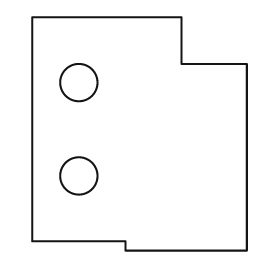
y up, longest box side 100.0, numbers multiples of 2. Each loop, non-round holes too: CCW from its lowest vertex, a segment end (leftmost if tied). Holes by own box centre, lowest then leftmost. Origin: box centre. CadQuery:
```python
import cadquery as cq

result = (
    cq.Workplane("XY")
    .moveTo(-6.0, -50.0)
    .lineTo(46.0, -50.0)
    .lineTo(46.0, 30.0)
    .lineTo(18.0, 30.0)
    .lineTo(18.0, 50.0)
    .lineTo(-46.0, 50.0)
    .lineTo(-46.0, -46.0)
    .lineTo(-6.0, -46.0)
    .close()
    .moveTo(-26.0, -18.0)
    .circle(8.0)
    .moveTo(-26.0, 22.0)
    .circle(8.0)
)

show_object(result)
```